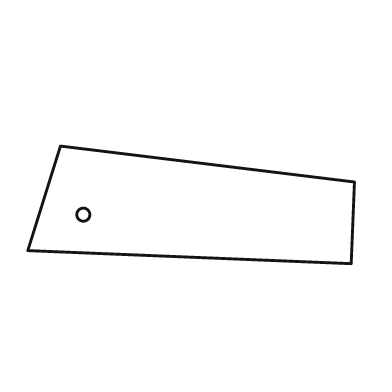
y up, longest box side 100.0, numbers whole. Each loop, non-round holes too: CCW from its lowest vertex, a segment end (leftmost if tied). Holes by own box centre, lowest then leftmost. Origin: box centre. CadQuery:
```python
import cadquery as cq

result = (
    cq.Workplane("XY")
    .moveTo(49.0, -18.0)
    .lineTo(50.0, 7.0)
    .lineTo(-40.0, 18.0)
    .lineTo(-50.0, -14.0)
    .close()
    .moveTo(-33.0, -3.0)
    .circle(2.0)
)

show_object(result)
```